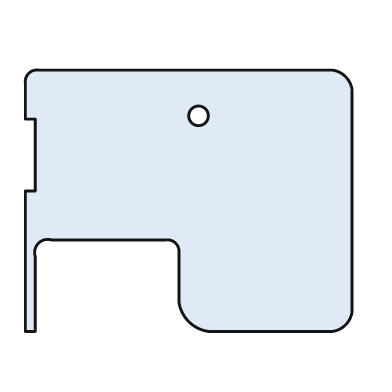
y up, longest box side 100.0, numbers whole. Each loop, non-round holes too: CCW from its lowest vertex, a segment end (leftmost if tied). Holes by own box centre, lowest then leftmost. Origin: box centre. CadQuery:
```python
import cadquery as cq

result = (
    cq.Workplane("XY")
    .moveTo(-50.0, -40.0)
    .lineTo(-47.0, -40.0)
    .lineTo(-47.0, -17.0)
    .threePointArc((-46.0, -13.0), (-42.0, -12.0))
    .lineTo(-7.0, -12.0)
    .threePointArc((-4.0, -13.0), (-3.0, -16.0))
    .lineTo(-3.0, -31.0)
    .threePointArc((0.0, -37.0), (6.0, -40.0))
    .lineTo(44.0, -40.0)
    .threePointArc((48.0, -38.0), (50.0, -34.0))
    .lineTo(50.0, 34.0)
    .threePointArc((48.0, 38.0), (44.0, 40.0))
    .lineTo(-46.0, 40.0)
    .threePointArc((-49.0, 39.0), (-50.0, 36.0))
    .lineTo(-50.0, 25.0)
    .lineTo(-47.0, 25.0)
    .lineTo(-47.0, 3.0)
    .lineTo(-50.0, 3.0)
    .close()
    .moveTo(3.0, 26.0)
    .circle(3.0)
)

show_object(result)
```